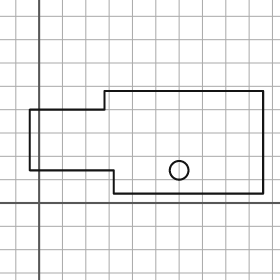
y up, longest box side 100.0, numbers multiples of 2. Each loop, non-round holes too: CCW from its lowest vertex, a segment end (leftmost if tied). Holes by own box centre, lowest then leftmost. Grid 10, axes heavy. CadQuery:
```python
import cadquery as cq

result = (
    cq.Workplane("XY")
    .moveTo(32.0, 4.0)
    .lineTo(96.0, 4.0)
    .lineTo(96.0, 48.0)
    .lineTo(28.0, 48.0)
    .lineTo(28.0, 40.0)
    .lineTo(-4.0, 40.0)
    .lineTo(-4.0, 14.0)
    .lineTo(32.0, 14.0)
    .close()
    .moveTo(60.0, 14.0)
    .circle(4.0)
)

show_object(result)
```